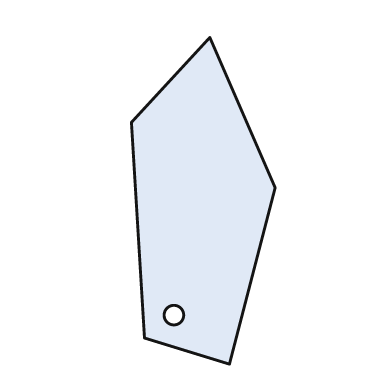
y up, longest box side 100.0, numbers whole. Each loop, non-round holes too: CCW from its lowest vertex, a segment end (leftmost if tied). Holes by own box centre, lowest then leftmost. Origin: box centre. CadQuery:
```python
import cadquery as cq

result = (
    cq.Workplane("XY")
    .moveTo(8.0, -50.0)
    .lineTo(22.0, 4.0)
    .lineTo(2.0, 50.0)
    .lineTo(-22.0, 24.0)
    .lineTo(-18.0, -42.0)
    .close()
    .moveTo(-9.0, -35.0)
    .circle(3.0)
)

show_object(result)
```